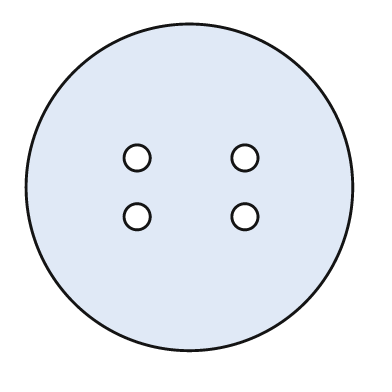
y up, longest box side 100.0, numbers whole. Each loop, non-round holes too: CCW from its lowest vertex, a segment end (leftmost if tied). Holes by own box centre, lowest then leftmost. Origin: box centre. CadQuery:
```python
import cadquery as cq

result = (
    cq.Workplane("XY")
    .moveTo(0.0, 0.0)
    .circle(50.0)
    .moveTo(-16.0, -9.0)
    .circle(4.0)
    .moveTo(17.0, -9.0)
    .circle(4.0)
    .moveTo(-16.0, 9.0)
    .circle(4.0)
    .moveTo(17.0, 9.0)
    .circle(4.0)
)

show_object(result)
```